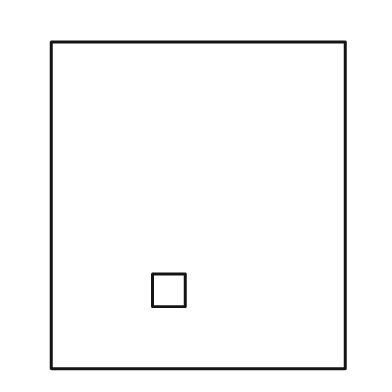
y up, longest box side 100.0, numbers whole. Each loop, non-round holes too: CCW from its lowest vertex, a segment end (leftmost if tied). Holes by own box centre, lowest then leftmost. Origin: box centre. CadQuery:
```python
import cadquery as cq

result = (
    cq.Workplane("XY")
    .moveTo(-45.0, -50.0)
    .lineTo(45.0, -50.0)
    .lineTo(45.0, 50.0)
    .lineTo(-45.0, 50.0)
    .close()
    .moveTo(-14.0, -31.0)
    .lineTo(-4.0, -31.0)
    .lineTo(-4.0, -21.0)
    .lineTo(-14.0, -21.0)
    .close()
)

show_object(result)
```